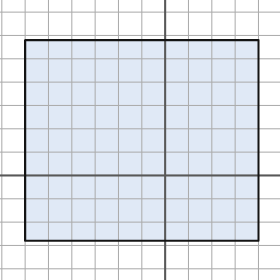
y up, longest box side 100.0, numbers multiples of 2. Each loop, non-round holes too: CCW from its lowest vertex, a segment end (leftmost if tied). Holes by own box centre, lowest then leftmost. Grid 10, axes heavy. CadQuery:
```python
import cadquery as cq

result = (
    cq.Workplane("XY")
    .moveTo(-60.0, -28.0)
    .lineTo(40.0, -28.0)
    .lineTo(40.0, 58.0)
    .lineTo(-60.0, 58.0)
    .close()
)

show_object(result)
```